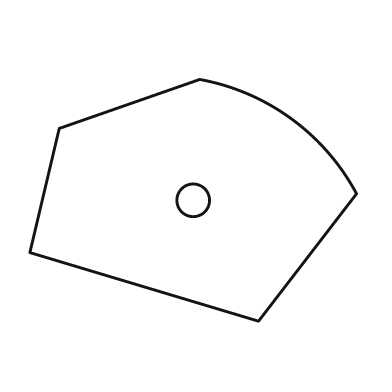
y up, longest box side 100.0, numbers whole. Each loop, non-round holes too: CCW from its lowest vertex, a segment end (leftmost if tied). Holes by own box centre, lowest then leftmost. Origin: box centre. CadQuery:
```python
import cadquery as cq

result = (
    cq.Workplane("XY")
    .moveTo(20.0, -37.0)
    .lineTo(50.0, 2.0)
    .threePointArc((30.0, 25.0), (2.0, 37.0))
    .lineTo(-41.0, 22.0)
    .lineTo(-50.0, -16.0)
    .close()
    .moveTo(0.0, 0.0)
    .circle(5.0)
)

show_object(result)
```